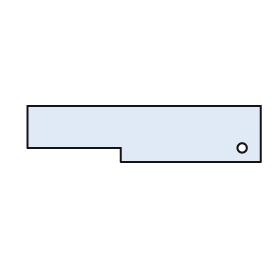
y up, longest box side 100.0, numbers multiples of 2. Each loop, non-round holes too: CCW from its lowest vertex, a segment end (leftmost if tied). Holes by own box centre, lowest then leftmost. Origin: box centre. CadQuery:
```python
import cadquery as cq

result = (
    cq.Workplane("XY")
    .moveTo(-10.0, -12.0)
    .lineTo(50.0, -12.0)
    .lineTo(50.0, 12.0)
    .lineTo(-50.0, 12.0)
    .lineTo(-50.0, -6.0)
    .lineTo(-10.0, -6.0)
    .close()
    .moveTo(42.0, -6.0)
    .circle(2.0)
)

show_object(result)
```